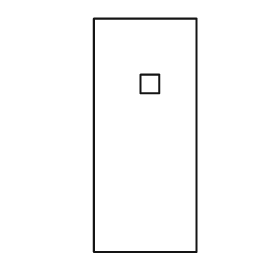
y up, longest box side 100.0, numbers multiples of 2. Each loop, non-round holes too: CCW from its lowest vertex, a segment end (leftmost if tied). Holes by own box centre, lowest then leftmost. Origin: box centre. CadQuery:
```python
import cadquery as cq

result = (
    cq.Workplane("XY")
    .moveTo(-22.0, -50.0)
    .lineTo(22.0, -50.0)
    .lineTo(22.0, 50.0)
    .lineTo(-22.0, 50.0)
    .close()
    .moveTo(-2.0, 18.0)
    .lineTo(6.0, 18.0)
    .lineTo(6.0, 26.0)
    .lineTo(-2.0, 26.0)
    .close()
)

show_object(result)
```